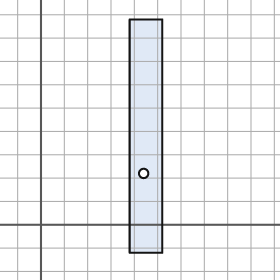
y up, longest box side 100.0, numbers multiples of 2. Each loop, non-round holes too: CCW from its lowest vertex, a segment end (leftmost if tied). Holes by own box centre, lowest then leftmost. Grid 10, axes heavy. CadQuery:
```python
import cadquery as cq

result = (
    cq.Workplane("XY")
    .moveTo(38.0, -12.0)
    .lineTo(52.0, -12.0)
    .lineTo(52.0, 88.0)
    .lineTo(38.0, 88.0)
    .close()
    .moveTo(44.0, 22.0)
    .circle(2.0)
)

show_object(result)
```